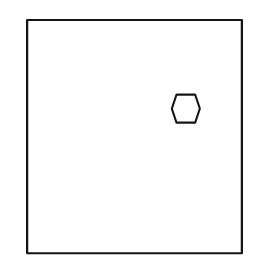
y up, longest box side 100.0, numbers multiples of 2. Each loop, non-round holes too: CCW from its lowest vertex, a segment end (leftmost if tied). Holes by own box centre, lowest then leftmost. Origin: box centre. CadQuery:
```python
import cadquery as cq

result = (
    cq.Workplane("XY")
    .moveTo(-46.0, -50.0)
    .lineTo(46.0, -50.0)
    .lineTo(46.0, 50.0)
    .lineTo(-46.0, 50.0)
    .close()
    .moveTo(18.0, 6.0)
    .lineTo(26.0, 6.0)
    .lineTo(28.0, 12.0)
    .lineTo(26.0, 18.0)
    .lineTo(18.0, 18.0)
    .lineTo(16.0, 12.0)
    .close()
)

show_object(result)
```